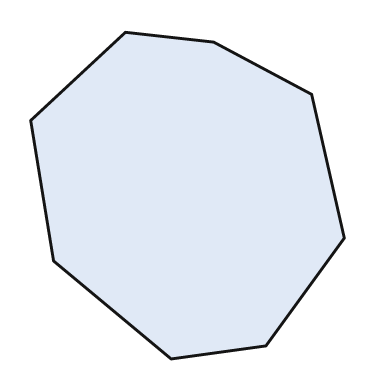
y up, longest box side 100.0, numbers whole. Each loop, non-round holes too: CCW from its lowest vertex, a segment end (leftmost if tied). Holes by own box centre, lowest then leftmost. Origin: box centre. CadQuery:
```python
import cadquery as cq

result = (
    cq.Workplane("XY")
    .moveTo(-5.0, -50.0)
    .lineTo(24.0, -46.0)
    .lineTo(48.0, -13.0)
    .lineTo(38.0, 31.0)
    .lineTo(8.0, 47.0)
    .lineTo(-19.0, 50.0)
    .lineTo(-48.0, 23.0)
    .lineTo(-41.0, -20.0)
    .close()
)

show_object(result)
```